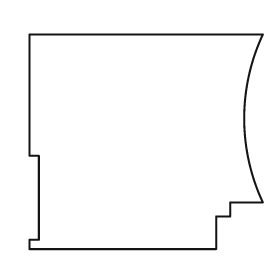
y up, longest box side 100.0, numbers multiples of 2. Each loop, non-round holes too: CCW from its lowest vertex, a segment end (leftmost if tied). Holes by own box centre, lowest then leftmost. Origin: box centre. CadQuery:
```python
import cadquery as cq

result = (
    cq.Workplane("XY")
    .moveTo(-50.0, -46.0)
    .lineTo(30.0, -46.0)
    .lineTo(30.0, -32.0)
    .lineTo(36.0, -32.0)
    .lineTo(36.0, -26.0)
    .lineTo(50.0, -26.0)
    .threePointArc((42.0, 10.0), (50.0, 46.0))
    .lineTo(-50.0, 46.0)
    .lineTo(-50.0, -6.0)
    .lineTo(-46.0, -6.0)
    .lineTo(-46.0, -42.0)
    .lineTo(-50.0, -42.0)
    .close()
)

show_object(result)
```